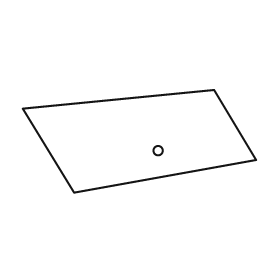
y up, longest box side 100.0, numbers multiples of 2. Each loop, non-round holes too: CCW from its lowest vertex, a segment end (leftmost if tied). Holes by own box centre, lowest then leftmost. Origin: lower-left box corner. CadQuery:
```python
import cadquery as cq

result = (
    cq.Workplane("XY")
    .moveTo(22.0, 0.0)
    .lineTo(100.0, 14.0)
    .lineTo(82.0, 44.0)
    .lineTo(0.0, 36.0)
    .close()
    .moveTo(58.0, 18.0)
    .circle(2.0)
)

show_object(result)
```